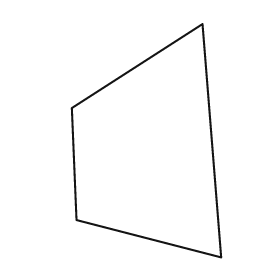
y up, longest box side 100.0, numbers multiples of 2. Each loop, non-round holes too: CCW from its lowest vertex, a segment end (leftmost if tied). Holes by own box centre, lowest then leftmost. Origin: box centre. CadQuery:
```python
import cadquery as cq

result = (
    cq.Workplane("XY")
    .moveTo(32.0, -50.0)
    .lineTo(24.0, 50.0)
    .lineTo(-32.0, 14.0)
    .lineTo(-30.0, -34.0)
    .close()
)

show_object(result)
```